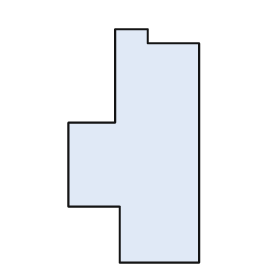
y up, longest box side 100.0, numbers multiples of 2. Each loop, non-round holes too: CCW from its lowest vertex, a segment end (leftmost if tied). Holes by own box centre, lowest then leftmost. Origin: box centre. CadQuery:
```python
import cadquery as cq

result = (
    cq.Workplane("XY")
    .moveTo(-6.0, -50.0)
    .lineTo(28.0, -50.0)
    .lineTo(28.0, 44.0)
    .lineTo(6.0, 44.0)
    .lineTo(6.0, 50.0)
    .lineTo(-8.0, 50.0)
    .lineTo(-8.0, 10.0)
    .lineTo(-28.0, 10.0)
    .lineTo(-28.0, -26.0)
    .lineTo(-6.0, -26.0)
    .close()
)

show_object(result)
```